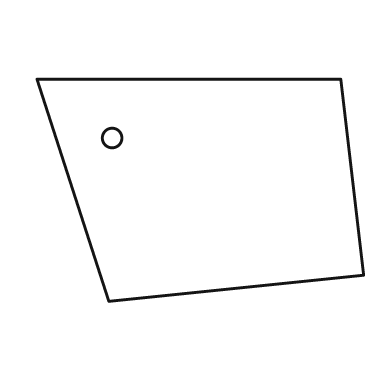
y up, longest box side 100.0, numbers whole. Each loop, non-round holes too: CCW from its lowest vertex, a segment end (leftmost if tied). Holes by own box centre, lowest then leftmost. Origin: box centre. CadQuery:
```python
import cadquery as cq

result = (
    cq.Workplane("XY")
    .moveTo(-28.0, -34.0)
    .lineTo(50.0, -26.0)
    .lineTo(43.0, 34.0)
    .lineTo(-50.0, 34.0)
    .close()
    .moveTo(-27.0, 16.0)
    .circle(3.0)
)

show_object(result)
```